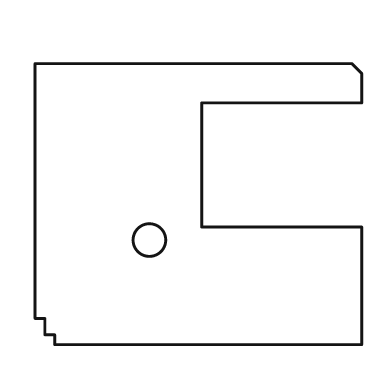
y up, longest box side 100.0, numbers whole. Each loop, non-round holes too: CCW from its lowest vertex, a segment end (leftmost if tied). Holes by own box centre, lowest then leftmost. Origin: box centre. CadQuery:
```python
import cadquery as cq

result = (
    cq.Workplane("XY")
    .moveTo(-44.0, -43.0)
    .lineTo(50.0, -43.0)
    .lineTo(50.0, -7.0)
    .lineTo(1.0, -7.0)
    .lineTo(1.0, 31.0)
    .lineTo(50.0, 31.0)
    .lineTo(50.0, 40.0)
    .lineTo(47.0, 43.0)
    .lineTo(-50.0, 43.0)
    .lineTo(-50.0, -35.0)
    .lineTo(-47.0, -35.0)
    .lineTo(-47.0, -40.0)
    .lineTo(-44.0, -40.0)
    .close()
    .moveTo(-15.0, -11.0)
    .circle(5.0)
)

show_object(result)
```